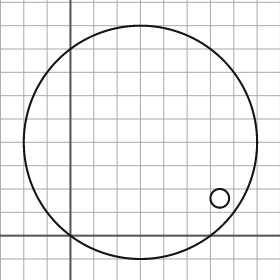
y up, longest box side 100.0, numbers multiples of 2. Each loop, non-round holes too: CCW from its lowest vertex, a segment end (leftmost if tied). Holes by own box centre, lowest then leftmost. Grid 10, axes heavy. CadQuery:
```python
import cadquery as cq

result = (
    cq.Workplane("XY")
    .moveTo(30.0, 40.0)
    .circle(50.0)
    .moveTo(64.0, 16.0)
    .circle(4.0)
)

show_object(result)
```